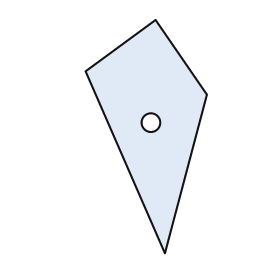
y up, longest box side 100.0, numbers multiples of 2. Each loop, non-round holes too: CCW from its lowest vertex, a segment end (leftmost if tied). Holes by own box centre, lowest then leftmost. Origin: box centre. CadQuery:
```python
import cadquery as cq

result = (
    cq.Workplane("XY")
    .moveTo(8.0, -50.0)
    .lineTo(26.0, 18.0)
    .lineTo(4.0, 50.0)
    .lineTo(-26.0, 28.0)
    .close()
    .moveTo(2.0, 6.0)
    .circle(4.0)
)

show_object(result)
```